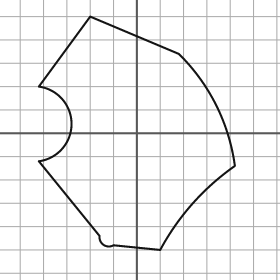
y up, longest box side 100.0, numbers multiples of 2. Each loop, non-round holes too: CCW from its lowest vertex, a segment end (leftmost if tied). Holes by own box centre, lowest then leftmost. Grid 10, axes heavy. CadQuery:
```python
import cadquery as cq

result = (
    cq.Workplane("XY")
    .moveTo(10.0, -50.0)
    .threePointArc((24.0, -30.0), (42.0, -14.0))
    .threePointArc((34.0, 12.0), (18.0, 34.0))
    .lineTo(-20.0, 50.0)
    .lineTo(-42.0, 20.0)
    .threePointArc((-28.0, 4.0), (-42.0, -12.0))
    .lineTo(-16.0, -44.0)
    .threePointArc((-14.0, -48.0), (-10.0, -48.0))
    .close()
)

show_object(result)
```